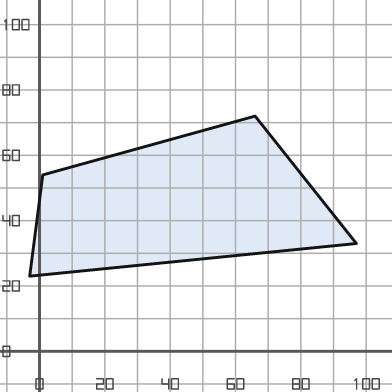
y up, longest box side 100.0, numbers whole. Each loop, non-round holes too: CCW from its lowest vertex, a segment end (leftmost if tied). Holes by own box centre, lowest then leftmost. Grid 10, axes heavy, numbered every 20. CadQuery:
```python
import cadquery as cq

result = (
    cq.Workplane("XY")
    .moveTo(-3.0, 23.0)
    .lineTo(97.0, 33.0)
    .lineTo(66.0, 72.0)
    .lineTo(1.0, 54.0)
    .close()
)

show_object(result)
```